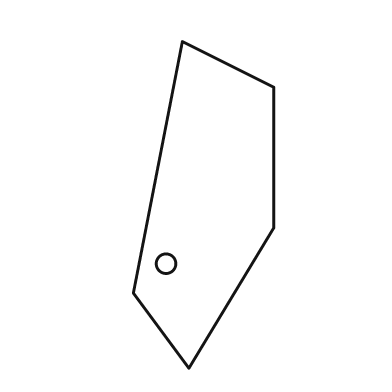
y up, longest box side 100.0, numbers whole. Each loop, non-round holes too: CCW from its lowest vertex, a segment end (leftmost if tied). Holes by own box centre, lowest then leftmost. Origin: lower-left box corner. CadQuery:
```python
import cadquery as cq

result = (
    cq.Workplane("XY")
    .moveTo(17.0, 0.0)
    .lineTo(43.0, 43.0)
    .lineTo(43.0, 86.0)
    .lineTo(15.0, 100.0)
    .lineTo(0.0, 23.0)
    .close()
    .moveTo(10.0, 32.0)
    .circle(3.0)
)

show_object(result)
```